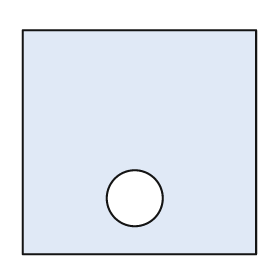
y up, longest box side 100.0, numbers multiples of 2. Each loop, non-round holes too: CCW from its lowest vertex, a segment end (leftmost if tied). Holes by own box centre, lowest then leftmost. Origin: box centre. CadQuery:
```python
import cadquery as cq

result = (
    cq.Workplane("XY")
    .moveTo(-50.0, -48.0)
    .lineTo(50.0, -48.0)
    .lineTo(50.0, 48.0)
    .lineTo(-50.0, 48.0)
    .close()
    .moveTo(-2.0, -24.0)
    .circle(12.0)
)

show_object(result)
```